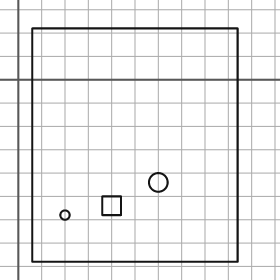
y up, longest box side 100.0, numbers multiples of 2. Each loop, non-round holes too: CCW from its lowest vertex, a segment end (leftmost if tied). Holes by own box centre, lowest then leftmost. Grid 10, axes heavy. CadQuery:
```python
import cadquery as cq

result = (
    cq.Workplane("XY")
    .moveTo(6.0, -78.0)
    .lineTo(94.0, -78.0)
    .lineTo(94.0, 22.0)
    .lineTo(6.0, 22.0)
    .close()
    .moveTo(20.0, -58.0)
    .circle(2.0)
    .moveTo(36.0, -58.0)
    .lineTo(44.0, -58.0)
    .lineTo(44.0, -50.0)
    .lineTo(36.0, -50.0)
    .close()
    .moveTo(60.0, -44.0)
    .circle(4.0)
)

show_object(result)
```